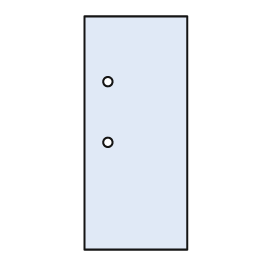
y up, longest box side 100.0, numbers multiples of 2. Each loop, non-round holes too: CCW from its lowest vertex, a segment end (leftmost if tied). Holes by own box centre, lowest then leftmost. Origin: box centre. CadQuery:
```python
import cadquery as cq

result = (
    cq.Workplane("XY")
    .moveTo(-22.0, -50.0)
    .lineTo(22.0, -50.0)
    .lineTo(22.0, 50.0)
    .lineTo(-22.0, 50.0)
    .close()
    .moveTo(-12.0, -4.0)
    .circle(2.0)
    .moveTo(-12.0, 22.0)
    .circle(2.0)
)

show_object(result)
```